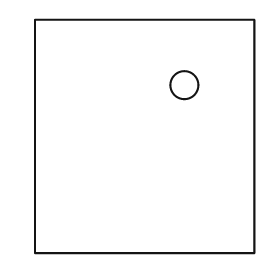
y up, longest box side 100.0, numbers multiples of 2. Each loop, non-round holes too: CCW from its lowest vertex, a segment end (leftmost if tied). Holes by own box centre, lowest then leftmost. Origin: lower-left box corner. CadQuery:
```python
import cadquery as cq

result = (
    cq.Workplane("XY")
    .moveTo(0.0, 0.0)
    .lineTo(94.0, 0.0)
    .lineTo(94.0, 100.0)
    .lineTo(0.0, 100.0)
    .close()
    .moveTo(64.0, 72.0)
    .circle(6.0)
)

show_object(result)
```